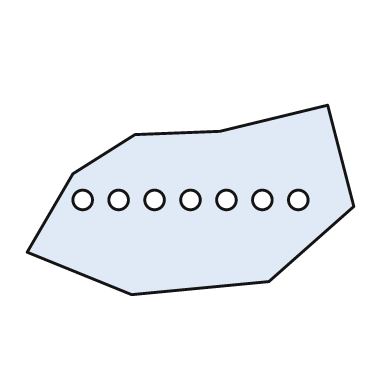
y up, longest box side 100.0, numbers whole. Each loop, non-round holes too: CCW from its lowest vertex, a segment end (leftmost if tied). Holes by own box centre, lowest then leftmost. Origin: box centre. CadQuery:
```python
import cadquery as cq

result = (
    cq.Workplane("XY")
    .moveTo(-18.0, -29.0)
    .lineTo(24.0, -25.0)
    .lineTo(50.0, -2.0)
    .lineTo(42.0, 29.0)
    .lineTo(9.0, 21.0)
    .lineTo(-17.0, 20.0)
    .lineTo(-36.0, 8.0)
    .lineTo(-50.0, -16.0)
    .close()
    .moveTo(-33.0, 0.0)
    .circle(3.0)
    .moveTo(-22.0, 0.0)
    .circle(3.0)
    .moveTo(-11.0, 0.0)
    .circle(3.0)
    .moveTo(0.0, 0.0)
    .circle(3.0)
    .moveTo(11.0, 0.0)
    .circle(3.0)
    .moveTo(22.0, 0.0)
    .circle(3.0)
    .moveTo(33.0, 0.0)
    .circle(3.0)
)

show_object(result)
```